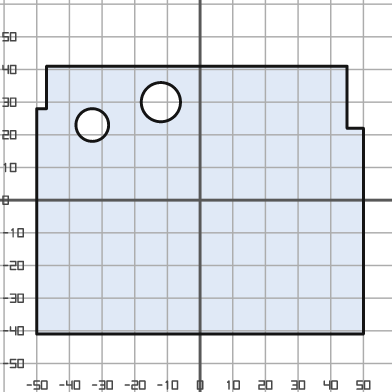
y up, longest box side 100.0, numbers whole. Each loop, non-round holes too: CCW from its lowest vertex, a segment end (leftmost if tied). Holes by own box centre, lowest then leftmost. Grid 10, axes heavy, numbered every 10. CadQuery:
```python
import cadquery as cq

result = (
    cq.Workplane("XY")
    .moveTo(-50.0, -41.0)
    .lineTo(50.0, -41.0)
    .lineTo(50.0, 22.0)
    .lineTo(45.0, 22.0)
    .lineTo(45.0, 41.0)
    .lineTo(-47.0, 41.0)
    .lineTo(-47.0, 28.0)
    .lineTo(-50.0, 28.0)
    .close()
    .moveTo(-33.0, 23.0)
    .circle(5.0)
    .moveTo(-12.0, 30.0)
    .circle(6.0)
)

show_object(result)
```